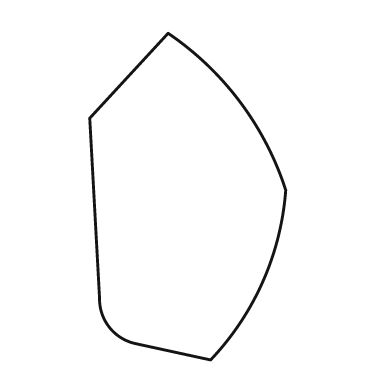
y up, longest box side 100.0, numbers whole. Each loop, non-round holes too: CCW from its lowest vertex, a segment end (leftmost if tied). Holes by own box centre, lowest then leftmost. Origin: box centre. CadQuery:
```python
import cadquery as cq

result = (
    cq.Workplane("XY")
    .moveTo(7.0, -50.0)
    .threePointArc((23.0, -26.0), (30.0, 2.0))
    .threePointArc((16.0, 29.0), (-6.0, 50.0))
    .lineTo(-30.0, 24.0)
    .lineTo(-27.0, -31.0)
    .threePointArc((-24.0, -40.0), (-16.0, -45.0))
    .close()
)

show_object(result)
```